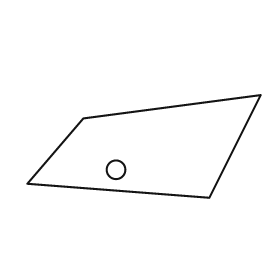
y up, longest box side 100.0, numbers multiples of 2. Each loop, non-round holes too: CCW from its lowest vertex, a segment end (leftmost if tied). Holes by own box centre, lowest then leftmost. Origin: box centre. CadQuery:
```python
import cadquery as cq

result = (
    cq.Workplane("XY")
    .moveTo(28.0, -22.0)
    .lineTo(50.0, 22.0)
    .lineTo(-26.0, 12.0)
    .lineTo(-50.0, -16.0)
    .close()
    .moveTo(-12.0, -10.0)
    .circle(4.0)
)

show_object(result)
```